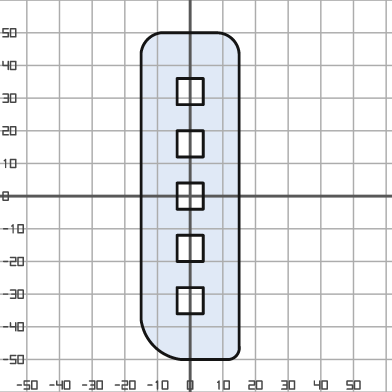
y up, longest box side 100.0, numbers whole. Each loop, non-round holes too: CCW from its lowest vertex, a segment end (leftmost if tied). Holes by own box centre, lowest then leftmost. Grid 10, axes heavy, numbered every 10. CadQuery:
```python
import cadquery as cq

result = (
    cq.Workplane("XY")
    .moveTo(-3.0, -50.0)
    .lineTo(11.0, -50.0)
    .threePointArc((14.0, -49.0), (15.0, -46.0))
    .lineTo(15.0, 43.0)
    .threePointArc((13.0, 48.0), (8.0, 50.0))
    .lineTo(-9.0, 50.0)
    .threePointArc((-13.0, 48.0), (-15.0, 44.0))
    .lineTo(-15.0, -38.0)
    .threePointArc((-11.0, -46.0), (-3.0, -50.0))
    .close()
    .moveTo(-4.0, -36.0)
    .lineTo(4.0, -36.0)
    .lineTo(4.0, -28.0)
    .lineTo(-4.0, -28.0)
    .close()
    .moveTo(-4.0, -20.0)
    .lineTo(4.0, -20.0)
    .lineTo(4.0, -12.0)
    .lineTo(-4.0, -12.0)
    .close()
    .moveTo(-4.0, -4.0)
    .lineTo(4.0, -4.0)
    .lineTo(4.0, 4.0)
    .lineTo(-4.0, 4.0)
    .close()
    .moveTo(-4.0, 12.0)
    .lineTo(4.0, 12.0)
    .lineTo(4.0, 20.0)
    .lineTo(-4.0, 20.0)
    .close()
    .moveTo(-4.0, 28.0)
    .lineTo(4.0, 28.0)
    .lineTo(4.0, 36.0)
    .lineTo(-4.0, 36.0)
    .close()
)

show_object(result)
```